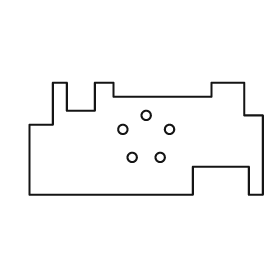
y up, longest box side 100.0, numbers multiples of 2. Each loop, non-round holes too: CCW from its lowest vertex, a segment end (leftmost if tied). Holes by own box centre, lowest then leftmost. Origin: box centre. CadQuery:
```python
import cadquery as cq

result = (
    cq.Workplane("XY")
    .moveTo(-50.0, -24.0)
    .lineTo(20.0, -24.0)
    .lineTo(20.0, -12.0)
    .lineTo(44.0, -12.0)
    .lineTo(44.0, -24.0)
    .lineTo(50.0, -24.0)
    .lineTo(50.0, 10.0)
    .lineTo(42.0, 10.0)
    .lineTo(42.0, 24.0)
    .lineTo(28.0, 24.0)
    .lineTo(28.0, 18.0)
    .lineTo(-14.0, 18.0)
    .lineTo(-14.0, 24.0)
    .lineTo(-22.0, 24.0)
    .lineTo(-22.0, 12.0)
    .lineTo(-34.0, 12.0)
    .lineTo(-34.0, 24.0)
    .lineTo(-40.0, 24.0)
    .lineTo(-40.0, 6.0)
    .lineTo(-50.0, 6.0)
    .close()
    .moveTo(-6.0, -8.0)
    .circle(2.0)
    .moveTo(6.0, -8.0)
    .circle(2.0)
    .moveTo(-10.0, 4.0)
    .circle(2.0)
    .moveTo(10.0, 4.0)
    .circle(2.0)
    .moveTo(0.0, 10.0)
    .circle(2.0)
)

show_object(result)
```